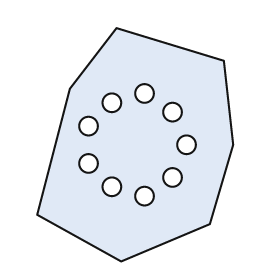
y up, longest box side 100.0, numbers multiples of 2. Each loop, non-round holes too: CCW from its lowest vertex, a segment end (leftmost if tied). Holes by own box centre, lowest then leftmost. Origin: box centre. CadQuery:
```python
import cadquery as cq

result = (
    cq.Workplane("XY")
    .moveTo(-6.0, -50.0)
    .lineTo(32.0, -34.0)
    .lineTo(42.0, 0.0)
    .lineTo(38.0, 36.0)
    .lineTo(-8.0, 50.0)
    .lineTo(-28.0, 24.0)
    .lineTo(-42.0, -30.0)
    .close()
    .moveTo(4.0, -22.0)
    .circle(4.0)
    .moveTo(-10.0, -18.0)
    .circle(4.0)
    .moveTo(16.0, -14.0)
    .circle(4.0)
    .moveTo(-20.0, -8.0)
    .circle(4.0)
    .moveTo(22.0, 0.0)
    .circle(4.0)
    .moveTo(-20.0, 8.0)
    .circle(4.0)
    .moveTo(16.0, 14.0)
    .circle(4.0)
    .moveTo(-10.0, 18.0)
    .circle(4.0)
    .moveTo(4.0, 22.0)
    .circle(4.0)
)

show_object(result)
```